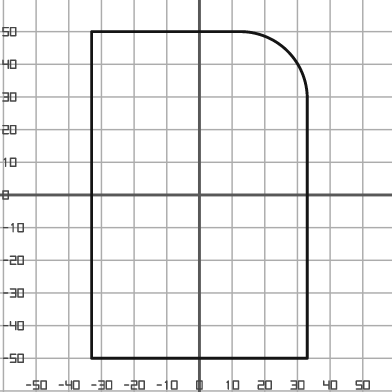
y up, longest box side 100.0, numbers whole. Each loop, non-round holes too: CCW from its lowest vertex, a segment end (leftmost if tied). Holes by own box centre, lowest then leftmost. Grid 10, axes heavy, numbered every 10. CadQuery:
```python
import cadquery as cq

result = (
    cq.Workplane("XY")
    .moveTo(-33.0, -50.0)
    .lineTo(33.0, -50.0)
    .lineTo(33.0, 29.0)
    .threePointArc((27.0, 44.0), (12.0, 50.0))
    .lineTo(-33.0, 50.0)
    .close()
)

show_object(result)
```